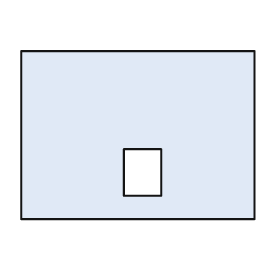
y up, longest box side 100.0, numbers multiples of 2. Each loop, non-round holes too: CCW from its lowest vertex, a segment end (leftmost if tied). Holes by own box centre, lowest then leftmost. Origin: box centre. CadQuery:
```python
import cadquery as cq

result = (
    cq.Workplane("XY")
    .moveTo(-50.0, -36.0)
    .lineTo(50.0, -36.0)
    .lineTo(50.0, 36.0)
    .lineTo(-50.0, 36.0)
    .close()
    .moveTo(-6.0, -26.0)
    .lineTo(10.0, -26.0)
    .lineTo(10.0, -6.0)
    .lineTo(-6.0, -6.0)
    .close()
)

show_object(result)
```